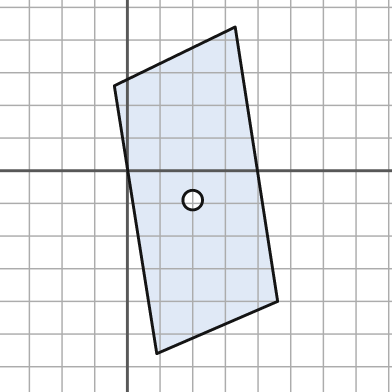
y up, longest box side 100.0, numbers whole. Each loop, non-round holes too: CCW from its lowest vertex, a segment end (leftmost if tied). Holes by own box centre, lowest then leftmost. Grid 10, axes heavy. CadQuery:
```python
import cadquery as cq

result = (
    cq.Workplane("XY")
    .moveTo(9.0, -56.0)
    .lineTo(46.0, -40.0)
    .lineTo(33.0, 44.0)
    .lineTo(-4.0, 26.0)
    .close()
    .moveTo(20.0, -9.0)
    .circle(3.0)
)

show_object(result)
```